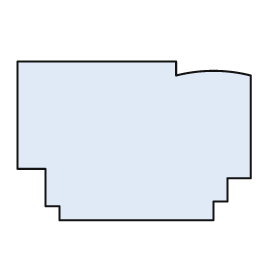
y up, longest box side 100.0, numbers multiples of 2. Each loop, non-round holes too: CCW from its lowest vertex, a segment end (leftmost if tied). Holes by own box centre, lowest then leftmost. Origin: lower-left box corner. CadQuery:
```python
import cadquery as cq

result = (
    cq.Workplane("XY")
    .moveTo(18.0, 0.0)
    .lineTo(84.0, 0.0)
    .lineTo(84.0, 8.0)
    .lineTo(90.0, 8.0)
    .lineTo(90.0, 18.0)
    .lineTo(100.0, 18.0)
    .lineTo(100.0, 62.0)
    .threePointArc((84.0, 64.0), (68.0, 62.0))
    .lineTo(68.0, 68.0)
    .lineTo(0.0, 68.0)
    .lineTo(0.0, 22.0)
    .lineTo(12.0, 22.0)
    .lineTo(12.0, 6.0)
    .lineTo(18.0, 6.0)
    .close()
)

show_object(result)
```